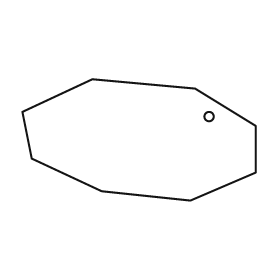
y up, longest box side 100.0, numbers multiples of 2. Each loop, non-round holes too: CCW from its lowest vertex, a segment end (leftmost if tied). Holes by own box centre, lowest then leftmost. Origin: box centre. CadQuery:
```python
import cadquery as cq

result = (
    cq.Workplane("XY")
    .moveTo(22.0, -26.0)
    .lineTo(50.0, -14.0)
    .lineTo(50.0, 6.0)
    .lineTo(24.0, 22.0)
    .lineTo(-20.0, 26.0)
    .lineTo(-50.0, 12.0)
    .lineTo(-46.0, -8.0)
    .lineTo(-16.0, -22.0)
    .close()
    .moveTo(30.0, 10.0)
    .circle(2.0)
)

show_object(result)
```